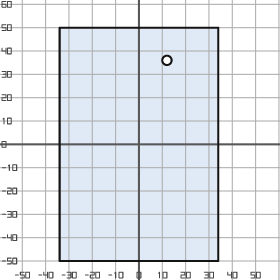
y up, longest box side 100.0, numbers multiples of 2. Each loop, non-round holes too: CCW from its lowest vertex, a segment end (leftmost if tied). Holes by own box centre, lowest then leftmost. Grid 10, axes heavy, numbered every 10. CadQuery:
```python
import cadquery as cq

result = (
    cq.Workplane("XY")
    .moveTo(-34.0, -50.0)
    .lineTo(34.0, -50.0)
    .lineTo(34.0, 50.0)
    .lineTo(-34.0, 50.0)
    .close()
    .moveTo(12.0, 36.0)
    .circle(2.0)
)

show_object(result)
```